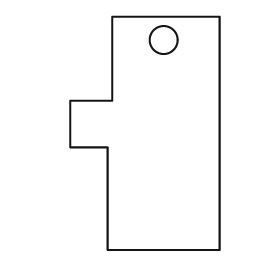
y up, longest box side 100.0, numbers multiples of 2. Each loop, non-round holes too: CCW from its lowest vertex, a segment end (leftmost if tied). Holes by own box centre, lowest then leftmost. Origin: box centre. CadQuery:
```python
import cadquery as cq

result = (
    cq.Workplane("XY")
    .moveTo(-16.0, -50.0)
    .lineTo(32.0, -50.0)
    .lineTo(32.0, 50.0)
    .lineTo(-14.0, 50.0)
    .lineTo(-14.0, 14.0)
    .lineTo(-32.0, 14.0)
    .lineTo(-32.0, -6.0)
    .lineTo(-16.0, -6.0)
    .close()
    .moveTo(8.0, 40.0)
    .circle(6.0)
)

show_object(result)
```